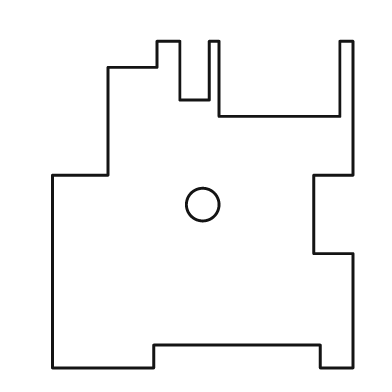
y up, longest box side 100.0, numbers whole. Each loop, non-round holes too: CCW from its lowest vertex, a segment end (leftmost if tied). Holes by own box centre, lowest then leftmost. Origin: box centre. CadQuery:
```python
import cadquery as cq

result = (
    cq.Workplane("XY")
    .moveTo(-46.0, -50.0)
    .lineTo(-15.0, -50.0)
    .lineTo(-15.0, -43.0)
    .lineTo(36.0, -43.0)
    .lineTo(36.0, -50.0)
    .lineTo(46.0, -50.0)
    .lineTo(46.0, -15.0)
    .lineTo(34.0, -15.0)
    .lineTo(34.0, 9.0)
    .lineTo(46.0, 9.0)
    .lineTo(46.0, 50.0)
    .lineTo(42.0, 50.0)
    .lineTo(42.0, 27.0)
    .lineTo(5.0, 27.0)
    .lineTo(5.0, 50.0)
    .lineTo(2.0, 50.0)
    .lineTo(2.0, 32.0)
    .lineTo(-7.0, 32.0)
    .lineTo(-7.0, 50.0)
    .lineTo(-14.0, 50.0)
    .lineTo(-14.0, 42.0)
    .lineTo(-29.0, 42.0)
    .lineTo(-29.0, 9.0)
    .lineTo(-46.0, 9.0)
    .close()
    .moveTo(0.0, 0.0)
    .circle(5.0)
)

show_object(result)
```